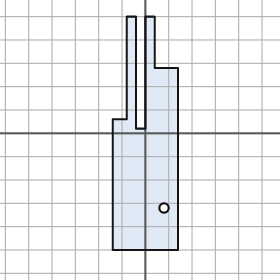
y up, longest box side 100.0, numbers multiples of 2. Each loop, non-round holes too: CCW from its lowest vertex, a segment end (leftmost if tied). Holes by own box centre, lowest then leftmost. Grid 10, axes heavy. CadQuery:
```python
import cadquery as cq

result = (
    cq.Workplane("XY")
    .moveTo(-14.0, -50.0)
    .lineTo(14.0, -50.0)
    .lineTo(14.0, 28.0)
    .lineTo(4.0, 28.0)
    .lineTo(4.0, 50.0)
    .lineTo(0.0, 50.0)
    .lineTo(0.0, 2.0)
    .lineTo(-4.0, 2.0)
    .lineTo(-4.0, 50.0)
    .lineTo(-8.0, 50.0)
    .lineTo(-8.0, 6.0)
    .lineTo(-14.0, 6.0)
    .close()
    .moveTo(8.0, -32.0)
    .circle(2.0)
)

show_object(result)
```